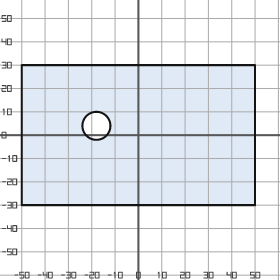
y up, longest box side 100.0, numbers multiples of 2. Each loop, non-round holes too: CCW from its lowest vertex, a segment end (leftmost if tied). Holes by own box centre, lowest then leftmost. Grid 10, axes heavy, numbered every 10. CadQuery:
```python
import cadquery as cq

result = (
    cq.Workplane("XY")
    .moveTo(-50.0, -30.0)
    .lineTo(50.0, -30.0)
    .lineTo(50.0, 30.0)
    .lineTo(-50.0, 30.0)
    .close()
    .moveTo(-18.0, 4.0)
    .circle(6.0)
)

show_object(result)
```